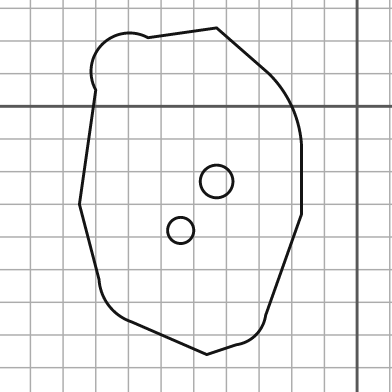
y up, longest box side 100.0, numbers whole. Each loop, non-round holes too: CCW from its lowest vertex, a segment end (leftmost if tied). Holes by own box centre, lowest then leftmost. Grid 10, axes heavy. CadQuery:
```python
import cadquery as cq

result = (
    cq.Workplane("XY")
    .moveTo(-46.0, -76.0)
    .lineTo(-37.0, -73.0)
    .threePointArc((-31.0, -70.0), (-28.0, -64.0))
    .lineTo(-17.0, -33.0)
    .lineTo(-17.0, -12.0)
    .threePointArc((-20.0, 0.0), (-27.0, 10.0))
    .lineTo(-43.0, 24.0)
    .lineTo(-64.0, 21.0)
    .threePointArc((-78.0, 19.0), (-80.0, 5.0))
    .lineTo(-85.0, -30.0)
    .lineTo(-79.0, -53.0)
    .threePointArc((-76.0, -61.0), (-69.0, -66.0))
    .close()
    .moveTo(-54.0, -38.0)
    .circle(4.0)
    .moveTo(-43.0, -23.0)
    .circle(5.0)
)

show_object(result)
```